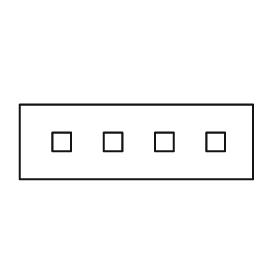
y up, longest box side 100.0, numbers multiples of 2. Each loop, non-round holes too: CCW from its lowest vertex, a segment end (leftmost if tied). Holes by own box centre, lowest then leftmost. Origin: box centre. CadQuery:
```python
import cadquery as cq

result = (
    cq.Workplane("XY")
    .moveTo(-50.0, -16.0)
    .lineTo(50.0, -16.0)
    .lineTo(50.0, 16.0)
    .lineTo(-50.0, 16.0)
    .close()
    .moveTo(-36.0, -4.0)
    .lineTo(-28.0, -4.0)
    .lineTo(-28.0, 4.0)
    .lineTo(-36.0, 4.0)
    .close()
    .moveTo(-14.0, -4.0)
    .lineTo(-6.0, -4.0)
    .lineTo(-6.0, 4.0)
    .lineTo(-14.0, 4.0)
    .close()
    .moveTo(8.0, -4.0)
    .lineTo(16.0, -4.0)
    .lineTo(16.0, 4.0)
    .lineTo(8.0, 4.0)
    .close()
    .moveTo(30.0, -4.0)
    .lineTo(38.0, -4.0)
    .lineTo(38.0, 4.0)
    .lineTo(30.0, 4.0)
    .close()
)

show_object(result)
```